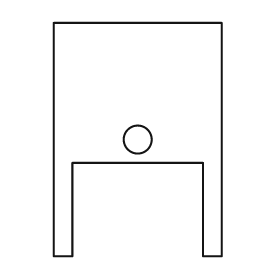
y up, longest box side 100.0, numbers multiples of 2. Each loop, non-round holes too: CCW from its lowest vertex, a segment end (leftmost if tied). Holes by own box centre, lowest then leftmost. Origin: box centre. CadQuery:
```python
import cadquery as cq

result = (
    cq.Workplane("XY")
    .moveTo(-36.0, -50.0)
    .lineTo(-28.0, -50.0)
    .lineTo(-28.0, -10.0)
    .lineTo(28.0, -10.0)
    .lineTo(28.0, -50.0)
    .lineTo(36.0, -50.0)
    .lineTo(36.0, 50.0)
    .lineTo(-36.0, 50.0)
    .close()
    .moveTo(0.0, 0.0)
    .circle(6.0)
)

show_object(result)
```